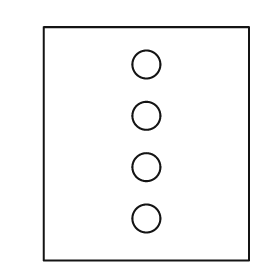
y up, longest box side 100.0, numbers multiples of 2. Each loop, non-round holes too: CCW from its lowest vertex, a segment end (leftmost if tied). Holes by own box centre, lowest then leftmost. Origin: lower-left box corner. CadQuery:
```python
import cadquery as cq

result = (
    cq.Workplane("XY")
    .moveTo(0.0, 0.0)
    .lineTo(88.0, 0.0)
    .lineTo(88.0, 100.0)
    .lineTo(0.0, 100.0)
    .close()
    .moveTo(44.0, 18.0)
    .circle(6.0)
    .moveTo(44.0, 40.0)
    .circle(6.0)
    .moveTo(44.0, 62.0)
    .circle(6.0)
    .moveTo(44.0, 84.0)
    .circle(6.0)
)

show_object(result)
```